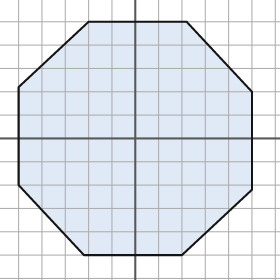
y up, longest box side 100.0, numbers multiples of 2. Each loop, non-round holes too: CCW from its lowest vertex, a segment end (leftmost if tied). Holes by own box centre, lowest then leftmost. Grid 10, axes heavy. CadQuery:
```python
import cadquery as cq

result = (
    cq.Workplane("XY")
    .moveTo(-22.0, -50.0)
    .lineTo(20.0, -50.0)
    .lineTo(50.0, -22.0)
    .lineTo(50.0, 20.0)
    .lineTo(22.0, 50.0)
    .lineTo(-20.0, 50.0)
    .lineTo(-50.0, 22.0)
    .lineTo(-50.0, -20.0)
    .close()
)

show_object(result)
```